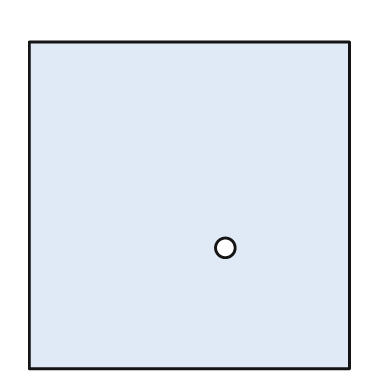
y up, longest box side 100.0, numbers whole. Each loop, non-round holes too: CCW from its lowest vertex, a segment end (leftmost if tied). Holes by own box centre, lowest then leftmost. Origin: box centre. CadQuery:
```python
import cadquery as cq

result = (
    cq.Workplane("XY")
    .moveTo(-49.0, -50.0)
    .lineTo(49.0, -50.0)
    .lineTo(49.0, 50.0)
    .lineTo(-49.0, 50.0)
    .close()
    .moveTo(11.0, -13.0)
    .circle(3.0)
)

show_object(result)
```